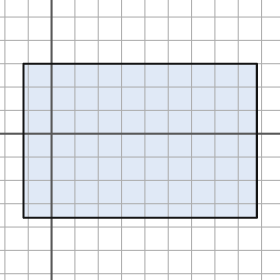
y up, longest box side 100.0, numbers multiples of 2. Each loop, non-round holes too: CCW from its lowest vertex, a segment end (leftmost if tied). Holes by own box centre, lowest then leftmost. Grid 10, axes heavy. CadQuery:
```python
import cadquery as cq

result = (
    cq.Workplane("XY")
    .moveTo(-12.0, -36.0)
    .lineTo(88.0, -36.0)
    .lineTo(88.0, 30.0)
    .lineTo(-12.0, 30.0)
    .close()
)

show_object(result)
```